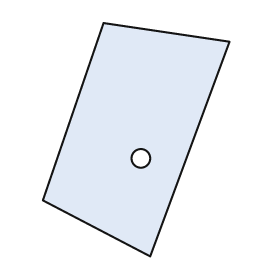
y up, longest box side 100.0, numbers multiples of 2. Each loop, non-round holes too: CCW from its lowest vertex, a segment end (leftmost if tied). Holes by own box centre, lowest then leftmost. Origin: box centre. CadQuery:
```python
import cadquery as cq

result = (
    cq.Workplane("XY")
    .moveTo(6.0, -50.0)
    .lineTo(40.0, 42.0)
    .lineTo(-14.0, 50.0)
    .lineTo(-40.0, -26.0)
    .close()
    .moveTo(2.0, -8.0)
    .circle(4.0)
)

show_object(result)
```